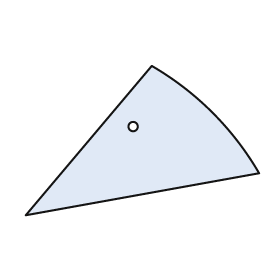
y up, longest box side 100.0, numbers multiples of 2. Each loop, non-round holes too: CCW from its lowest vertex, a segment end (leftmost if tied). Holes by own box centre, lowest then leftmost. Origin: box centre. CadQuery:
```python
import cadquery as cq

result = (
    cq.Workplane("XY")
    .moveTo(-50.0, -32.0)
    .lineTo(50.0, -14.0)
    .threePointArc((30.0, 12.0), (4.0, 32.0))
    .close()
    .moveTo(-4.0, 6.0)
    .circle(2.0)
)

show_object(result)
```